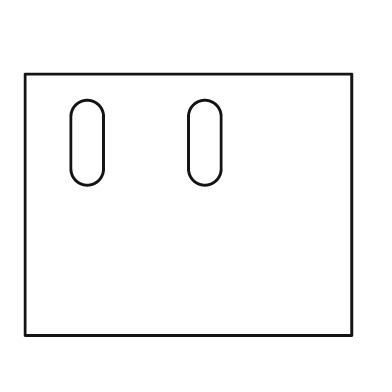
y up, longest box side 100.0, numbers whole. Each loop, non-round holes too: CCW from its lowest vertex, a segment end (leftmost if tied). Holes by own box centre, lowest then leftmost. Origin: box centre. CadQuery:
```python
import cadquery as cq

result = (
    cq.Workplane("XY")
    .moveTo(-50.0, -40.0)
    .lineTo(50.0, -40.0)
    .lineTo(50.0, 40.0)
    .lineTo(-50.0, 40.0)
    .close()
    .moveTo(-36.0, 11.0)
    .threePointArc((-31.0, 6.0), (-26.0, 11.0))
    .lineTo(-26.0, 27.0)
    .threePointArc((-31.0, 32.0), (-36.0, 27.0))
    .close()
    .moveTo(0.0, 11.0)
    .threePointArc((5.0, 6.0), (10.0, 11.0))
    .lineTo(10.0, 27.0)
    .threePointArc((5.0, 32.0), (0.0, 27.0))
    .close()
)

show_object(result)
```